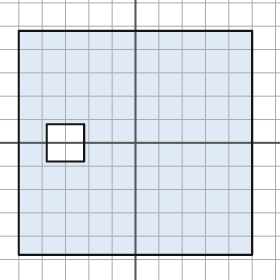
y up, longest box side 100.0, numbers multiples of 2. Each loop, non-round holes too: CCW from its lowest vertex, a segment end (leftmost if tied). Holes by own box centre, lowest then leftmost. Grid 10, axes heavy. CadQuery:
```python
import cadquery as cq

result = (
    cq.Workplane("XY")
    .moveTo(-50.0, -48.0)
    .lineTo(50.0, -48.0)
    .lineTo(50.0, 48.0)
    .lineTo(-50.0, 48.0)
    .close()
    .moveTo(-38.0, -8.0)
    .lineTo(-22.0, -8.0)
    .lineTo(-22.0, 8.0)
    .lineTo(-38.0, 8.0)
    .close()
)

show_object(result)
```